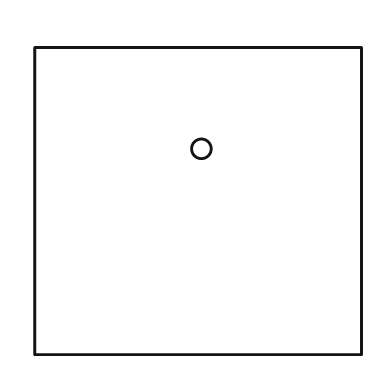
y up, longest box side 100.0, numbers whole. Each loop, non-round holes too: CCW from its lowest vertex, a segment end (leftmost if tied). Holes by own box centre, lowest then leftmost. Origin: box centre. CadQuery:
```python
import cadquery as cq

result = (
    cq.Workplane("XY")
    .moveTo(-50.0, -47.0)
    .lineTo(50.0, -47.0)
    .lineTo(50.0, 47.0)
    .lineTo(-50.0, 47.0)
    .close()
    .moveTo(1.0, 16.0)
    .circle(3.0)
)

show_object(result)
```